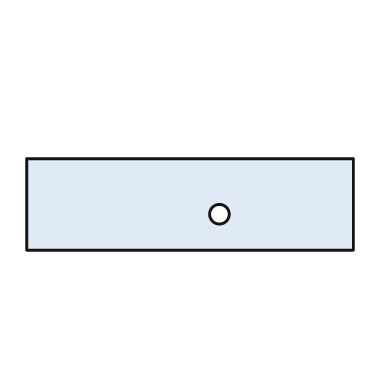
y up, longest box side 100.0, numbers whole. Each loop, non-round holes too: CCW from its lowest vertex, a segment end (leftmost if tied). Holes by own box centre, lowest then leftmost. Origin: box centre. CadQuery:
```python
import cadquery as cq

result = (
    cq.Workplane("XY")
    .moveTo(-50.0, -14.0)
    .lineTo(50.0, -14.0)
    .lineTo(50.0, 14.0)
    .lineTo(-50.0, 14.0)
    .close()
    .moveTo(9.0, -3.0)
    .circle(3.0)
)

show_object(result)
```